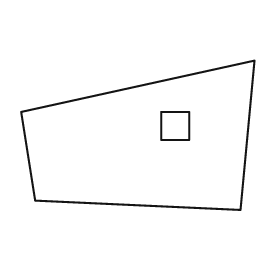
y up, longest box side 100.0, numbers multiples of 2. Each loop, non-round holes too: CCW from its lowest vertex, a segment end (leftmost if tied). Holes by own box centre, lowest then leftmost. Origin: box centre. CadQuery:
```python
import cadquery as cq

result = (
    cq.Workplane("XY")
    .moveTo(44.0, -32.0)
    .lineTo(50.0, 32.0)
    .lineTo(-50.0, 10.0)
    .lineTo(-44.0, -28.0)
    .close()
    .moveTo(10.0, -2.0)
    .lineTo(22.0, -2.0)
    .lineTo(22.0, 10.0)
    .lineTo(10.0, 10.0)
    .close()
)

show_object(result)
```